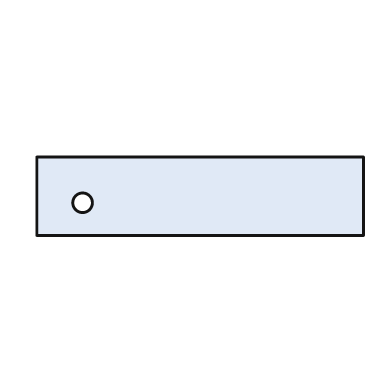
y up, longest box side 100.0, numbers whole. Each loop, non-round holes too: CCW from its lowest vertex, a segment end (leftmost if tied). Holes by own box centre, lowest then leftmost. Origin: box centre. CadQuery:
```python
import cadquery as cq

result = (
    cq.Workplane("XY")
    .moveTo(-50.0, -12.0)
    .lineTo(50.0, -12.0)
    .lineTo(50.0, 12.0)
    .lineTo(-50.0, 12.0)
    .close()
    .moveTo(-36.0, -2.0)
    .circle(3.0)
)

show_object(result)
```